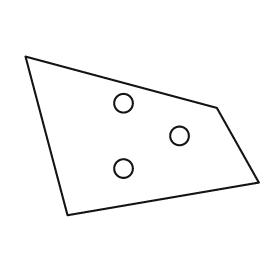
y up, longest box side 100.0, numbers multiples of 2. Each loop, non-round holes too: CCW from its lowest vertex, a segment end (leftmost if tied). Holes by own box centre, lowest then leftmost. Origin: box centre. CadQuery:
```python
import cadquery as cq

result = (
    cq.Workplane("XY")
    .moveTo(-32.0, -34.0)
    .lineTo(50.0, -20.0)
    .lineTo(32.0, 12.0)
    .lineTo(-50.0, 34.0)
    .close()
    .moveTo(-8.0, -14.0)
    .circle(4.0)
    .moveTo(16.0, 0.0)
    .circle(4.0)
    .moveTo(-8.0, 14.0)
    .circle(4.0)
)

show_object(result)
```